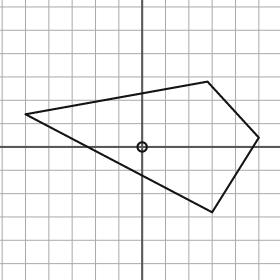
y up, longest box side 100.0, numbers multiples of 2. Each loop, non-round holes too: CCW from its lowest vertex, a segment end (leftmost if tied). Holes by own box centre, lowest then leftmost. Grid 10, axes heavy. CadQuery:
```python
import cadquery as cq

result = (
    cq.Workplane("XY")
    .moveTo(30.0, -28.0)
    .lineTo(50.0, 4.0)
    .lineTo(28.0, 28.0)
    .lineTo(-50.0, 14.0)
    .close()
    .moveTo(0.0, 0.0)
    .circle(2.0)
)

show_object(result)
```